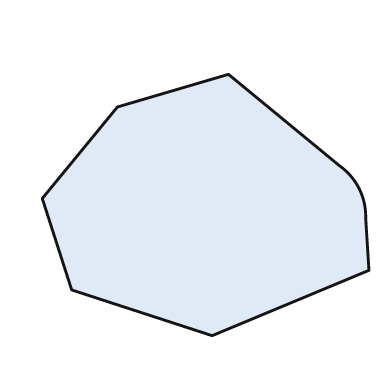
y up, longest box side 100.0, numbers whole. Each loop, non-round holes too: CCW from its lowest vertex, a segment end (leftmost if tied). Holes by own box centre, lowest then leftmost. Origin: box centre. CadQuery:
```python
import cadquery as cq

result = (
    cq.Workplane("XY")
    .moveTo(2.0, -40.0)
    .lineTo(50.0, -20.0)
    .lineTo(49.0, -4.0)
    .threePointArc((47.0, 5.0), (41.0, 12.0))
    .lineTo(7.0, 40.0)
    .lineTo(-27.0, 30.0)
    .lineTo(-50.0, 2.0)
    .lineTo(-41.0, -26.0)
    .close()
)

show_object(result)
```